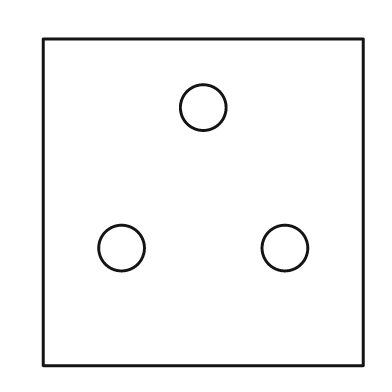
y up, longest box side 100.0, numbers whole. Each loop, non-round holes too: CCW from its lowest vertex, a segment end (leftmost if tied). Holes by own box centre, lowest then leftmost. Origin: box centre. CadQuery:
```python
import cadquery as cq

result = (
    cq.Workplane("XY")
    .moveTo(-49.0, -50.0)
    .lineTo(49.0, -50.0)
    .lineTo(49.0, 50.0)
    .lineTo(-49.0, 50.0)
    .close()
    .moveTo(-25.0, -14.0)
    .circle(7.0)
    .moveTo(25.0, -14.0)
    .circle(7.0)
    .moveTo(0.0, 29.0)
    .circle(7.0)
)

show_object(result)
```